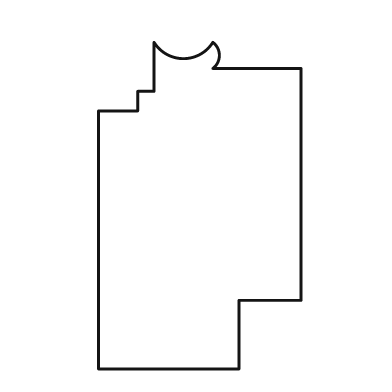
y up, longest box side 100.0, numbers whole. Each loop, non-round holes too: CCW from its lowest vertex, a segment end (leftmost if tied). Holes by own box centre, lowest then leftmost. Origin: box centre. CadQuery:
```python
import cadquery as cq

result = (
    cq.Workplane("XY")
    .moveTo(-31.0, -50.0)
    .lineTo(12.0, -50.0)
    .lineTo(12.0, -29.0)
    .lineTo(31.0, -29.0)
    .lineTo(31.0, 42.0)
    .lineTo(4.0, 42.0)
    .threePointArc((6.0, 46.0), (4.0, 50.0))
    .threePointArc((-5.0, 45.0), (-14.0, 50.0))
    .lineTo(-14.0, 35.0)
    .lineTo(-19.0, 35.0)
    .lineTo(-19.0, 29.0)
    .lineTo(-31.0, 29.0)
    .close()
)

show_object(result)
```